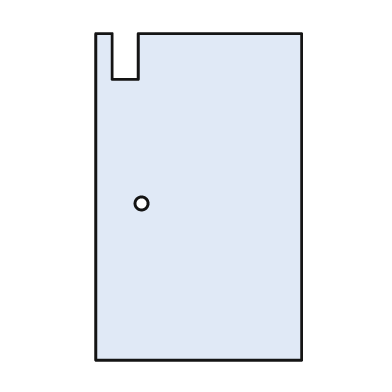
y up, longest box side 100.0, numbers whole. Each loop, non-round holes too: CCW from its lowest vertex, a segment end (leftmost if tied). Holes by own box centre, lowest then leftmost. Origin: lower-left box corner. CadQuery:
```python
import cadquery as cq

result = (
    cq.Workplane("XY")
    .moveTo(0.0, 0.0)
    .lineTo(63.0, 0.0)
    .lineTo(63.0, 100.0)
    .lineTo(13.0, 100.0)
    .lineTo(13.0, 86.0)
    .lineTo(5.0, 86.0)
    .lineTo(5.0, 100.0)
    .lineTo(0.0, 100.0)
    .close()
    .moveTo(14.0, 48.0)
    .circle(2.0)
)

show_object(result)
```